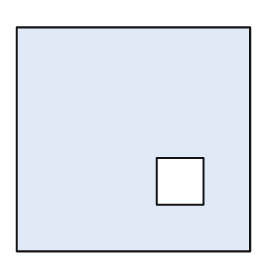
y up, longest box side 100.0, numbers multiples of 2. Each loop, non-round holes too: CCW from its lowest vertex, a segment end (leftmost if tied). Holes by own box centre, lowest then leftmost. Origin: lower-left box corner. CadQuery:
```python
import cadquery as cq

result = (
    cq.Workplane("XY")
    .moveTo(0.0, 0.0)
    .lineTo(100.0, 0.0)
    .lineTo(100.0, 96.0)
    .lineTo(0.0, 96.0)
    .close()
    .moveTo(60.0, 20.0)
    .lineTo(80.0, 20.0)
    .lineTo(80.0, 40.0)
    .lineTo(60.0, 40.0)
    .close()
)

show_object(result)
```